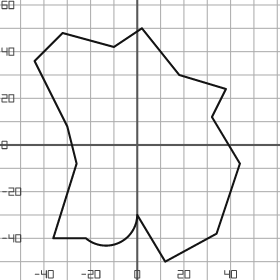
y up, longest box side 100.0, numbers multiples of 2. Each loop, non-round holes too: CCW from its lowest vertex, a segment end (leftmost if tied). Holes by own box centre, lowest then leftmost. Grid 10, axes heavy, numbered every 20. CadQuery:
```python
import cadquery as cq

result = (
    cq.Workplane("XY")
    .moveTo(12.0, -50.0)
    .lineTo(34.0, -38.0)
    .lineTo(44.0, -8.0)
    .lineTo(32.0, 12.0)
    .lineTo(38.0, 24.0)
    .lineTo(18.0, 30.0)
    .lineTo(2.0, 50.0)
    .lineTo(-10.0, 42.0)
    .lineTo(-32.0, 48.0)
    .lineTo(-44.0, 36.0)
    .lineTo(-30.0, 8.0)
    .lineTo(-26.0, -8.0)
    .lineTo(-36.0, -40.0)
    .lineTo(-22.0, -40.0)
    .threePointArc((-8.0, -42.0), (0.0, -30.0))
    .close()
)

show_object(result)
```